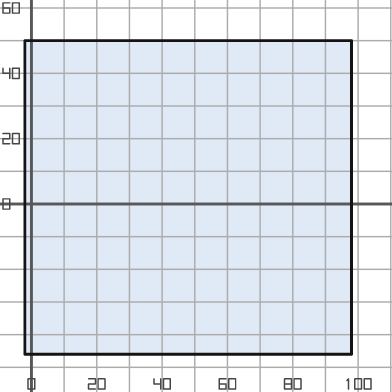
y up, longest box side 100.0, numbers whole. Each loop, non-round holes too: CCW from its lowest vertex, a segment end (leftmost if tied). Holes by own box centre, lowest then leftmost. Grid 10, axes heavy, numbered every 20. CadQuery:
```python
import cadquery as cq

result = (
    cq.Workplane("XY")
    .moveTo(-2.0, -46.0)
    .lineTo(98.0, -46.0)
    .lineTo(98.0, 50.0)
    .lineTo(-2.0, 50.0)
    .close()
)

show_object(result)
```